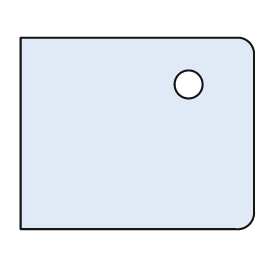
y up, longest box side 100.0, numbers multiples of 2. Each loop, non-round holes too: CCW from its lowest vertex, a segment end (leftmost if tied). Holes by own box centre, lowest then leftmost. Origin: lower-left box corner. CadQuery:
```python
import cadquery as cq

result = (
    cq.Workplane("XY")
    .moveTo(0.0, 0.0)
    .lineTo(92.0, 0.0)
    .threePointArc((98.0, 2.0), (100.0, 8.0))
    .lineTo(100.0, 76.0)
    .threePointArc((98.0, 80.0), (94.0, 82.0))
    .lineTo(0.0, 82.0)
    .close()
    .moveTo(72.0, 62.0)
    .circle(6.0)
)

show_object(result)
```